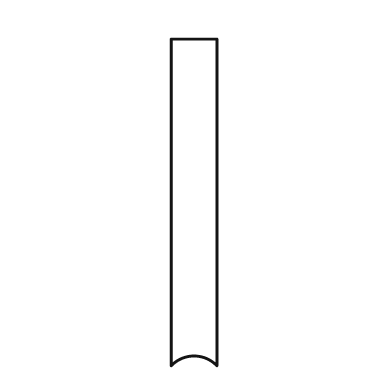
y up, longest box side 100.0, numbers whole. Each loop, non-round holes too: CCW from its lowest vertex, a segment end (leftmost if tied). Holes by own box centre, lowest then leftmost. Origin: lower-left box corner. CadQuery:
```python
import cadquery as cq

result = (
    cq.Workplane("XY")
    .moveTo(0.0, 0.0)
    .threePointArc((7.0, 3.0), (14.0, 0.0))
    .lineTo(14.0, 100.0)
    .lineTo(0.0, 100.0)
    .close()
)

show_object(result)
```